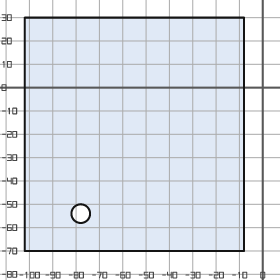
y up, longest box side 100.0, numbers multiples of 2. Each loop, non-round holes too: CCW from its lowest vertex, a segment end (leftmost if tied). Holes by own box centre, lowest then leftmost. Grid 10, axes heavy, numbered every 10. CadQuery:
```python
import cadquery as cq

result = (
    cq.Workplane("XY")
    .moveTo(-102.0, -70.0)
    .lineTo(-8.0, -70.0)
    .lineTo(-8.0, 30.0)
    .lineTo(-102.0, 30.0)
    .close()
    .moveTo(-78.0, -54.0)
    .circle(4.0)
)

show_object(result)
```